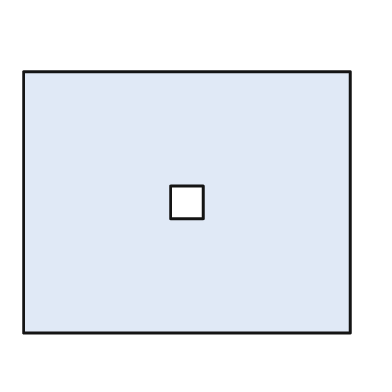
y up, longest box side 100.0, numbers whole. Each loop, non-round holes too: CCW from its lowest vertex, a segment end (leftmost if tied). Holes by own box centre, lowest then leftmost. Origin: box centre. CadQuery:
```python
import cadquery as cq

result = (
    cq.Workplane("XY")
    .moveTo(-50.0, -40.0)
    .lineTo(50.0, -40.0)
    .lineTo(50.0, 40.0)
    .lineTo(-50.0, 40.0)
    .close()
    .moveTo(-5.0, -5.0)
    .lineTo(5.0, -5.0)
    .lineTo(5.0, 5.0)
    .lineTo(-5.0, 5.0)
    .close()
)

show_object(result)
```